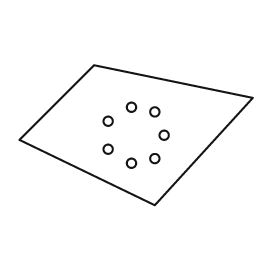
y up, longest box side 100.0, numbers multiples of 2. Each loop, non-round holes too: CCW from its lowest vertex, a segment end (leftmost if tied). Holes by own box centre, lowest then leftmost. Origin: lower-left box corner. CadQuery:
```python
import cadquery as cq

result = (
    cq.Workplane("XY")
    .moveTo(58.0, 0.0)
    .lineTo(100.0, 46.0)
    .lineTo(32.0, 60.0)
    .lineTo(0.0, 28.0)
    .close()
    .moveTo(48.0, 18.0)
    .circle(2.0)
    .moveTo(58.0, 20.0)
    .circle(2.0)
    .moveTo(38.0, 24.0)
    .circle(2.0)
    .moveTo(62.0, 30.0)
    .circle(2.0)
    .moveTo(38.0, 36.0)
    .circle(2.0)
    .moveTo(58.0, 40.0)
    .circle(2.0)
    .moveTo(48.0, 42.0)
    .circle(2.0)
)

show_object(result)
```